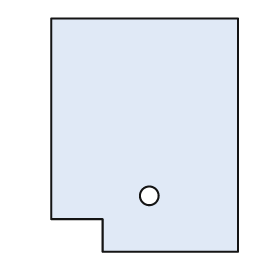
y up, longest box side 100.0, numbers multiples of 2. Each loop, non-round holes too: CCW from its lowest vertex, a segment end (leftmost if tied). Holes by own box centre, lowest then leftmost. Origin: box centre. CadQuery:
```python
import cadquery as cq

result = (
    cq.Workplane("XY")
    .moveTo(-18.0, -50.0)
    .lineTo(40.0, -50.0)
    .lineTo(40.0, 50.0)
    .lineTo(-40.0, 50.0)
    .lineTo(-40.0, -36.0)
    .lineTo(-18.0, -36.0)
    .close()
    .moveTo(2.0, -26.0)
    .circle(4.0)
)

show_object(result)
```